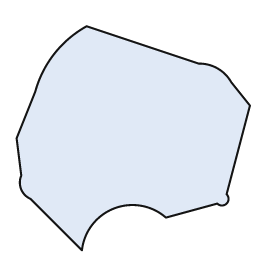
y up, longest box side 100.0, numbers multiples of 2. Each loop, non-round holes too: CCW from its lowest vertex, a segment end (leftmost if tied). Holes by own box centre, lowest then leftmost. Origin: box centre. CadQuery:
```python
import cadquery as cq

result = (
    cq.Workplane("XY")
    .moveTo(-22.0, -48.0)
    .threePointArc((-8.0, -30.0), (14.0, -34.0))
    .lineTo(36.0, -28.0)
    .threePointArc((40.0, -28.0), (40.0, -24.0))
    .lineTo(50.0, 14.0)
    .lineTo(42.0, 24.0)
    .threePointArc((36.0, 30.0), (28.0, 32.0))
    .lineTo(-20.0, 48.0)
    .threePointArc((-34.0, 36.0), (-42.0, 20.0))
    .lineTo(-50.0, 0.0)
    .lineTo(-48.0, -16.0)
    .threePointArc((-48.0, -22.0), (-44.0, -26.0))
    .close()
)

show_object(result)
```